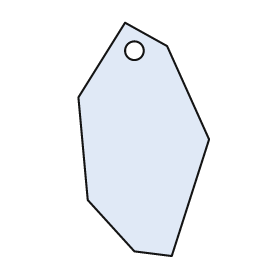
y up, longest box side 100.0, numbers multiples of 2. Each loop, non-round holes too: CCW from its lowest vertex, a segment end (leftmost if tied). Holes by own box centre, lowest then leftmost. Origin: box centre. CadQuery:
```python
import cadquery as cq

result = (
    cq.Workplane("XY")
    .moveTo(12.0, -50.0)
    .lineTo(28.0, 0.0)
    .lineTo(10.0, 40.0)
    .lineTo(-8.0, 50.0)
    .lineTo(-28.0, 18.0)
    .lineTo(-24.0, -26.0)
    .lineTo(-4.0, -48.0)
    .close()
    .moveTo(-4.0, 38.0)
    .circle(4.0)
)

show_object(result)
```